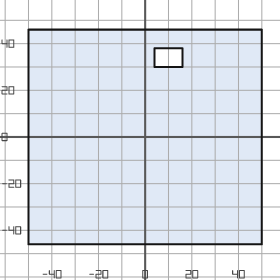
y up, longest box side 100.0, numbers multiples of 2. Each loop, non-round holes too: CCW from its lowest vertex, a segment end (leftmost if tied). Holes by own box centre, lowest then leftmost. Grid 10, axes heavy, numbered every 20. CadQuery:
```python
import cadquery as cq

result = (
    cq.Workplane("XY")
    .moveTo(-50.0, -46.0)
    .lineTo(50.0, -46.0)
    .lineTo(50.0, 46.0)
    .lineTo(-50.0, 46.0)
    .close()
    .moveTo(4.0, 30.0)
    .lineTo(16.0, 30.0)
    .lineTo(16.0, 38.0)
    .lineTo(4.0, 38.0)
    .close()
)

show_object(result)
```